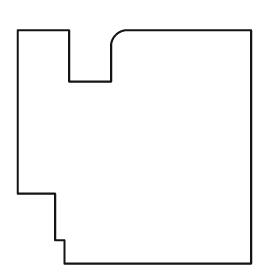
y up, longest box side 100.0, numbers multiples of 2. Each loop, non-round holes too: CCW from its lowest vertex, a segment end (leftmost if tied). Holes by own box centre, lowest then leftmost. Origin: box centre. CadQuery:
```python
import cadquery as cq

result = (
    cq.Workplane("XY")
    .moveTo(-30.0, -50.0)
    .lineTo(50.0, -50.0)
    .lineTo(50.0, 50.0)
    .lineTo(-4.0, 50.0)
    .threePointArc((-8.0, 48.0), (-10.0, 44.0))
    .lineTo(-10.0, 28.0)
    .lineTo(-28.0, 28.0)
    .lineTo(-28.0, 50.0)
    .lineTo(-50.0, 50.0)
    .lineTo(-50.0, -20.0)
    .lineTo(-34.0, -20.0)
    .lineTo(-34.0, -40.0)
    .lineTo(-30.0, -40.0)
    .close()
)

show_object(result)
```